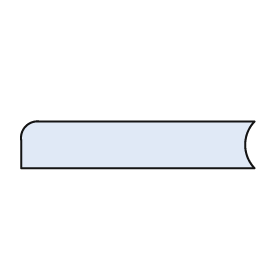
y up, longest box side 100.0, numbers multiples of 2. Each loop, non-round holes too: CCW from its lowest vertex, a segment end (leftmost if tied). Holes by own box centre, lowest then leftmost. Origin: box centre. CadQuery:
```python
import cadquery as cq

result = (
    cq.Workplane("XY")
    .moveTo(-50.0, -10.0)
    .lineTo(50.0, -10.0)
    .threePointArc((46.0, 0.0), (50.0, 10.0))
    .lineTo(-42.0, 10.0)
    .threePointArc((-48.0, 8.0), (-50.0, 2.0))
    .close()
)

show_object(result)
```